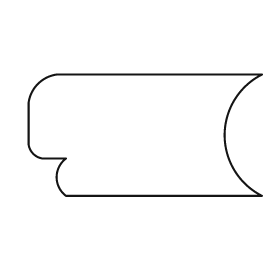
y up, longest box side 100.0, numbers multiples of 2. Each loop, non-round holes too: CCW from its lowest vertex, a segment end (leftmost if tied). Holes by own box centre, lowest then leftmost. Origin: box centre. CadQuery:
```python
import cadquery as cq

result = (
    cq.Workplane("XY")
    .moveTo(-34.0, -26.0)
    .lineTo(50.0, -26.0)
    .threePointArc((34.0, 0.0), (50.0, 26.0))
    .lineTo(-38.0, 26.0)
    .threePointArc((-46.0, 22.0), (-50.0, 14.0))
    .lineTo(-50.0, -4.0)
    .threePointArc((-48.0, -8.0), (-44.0, -10.0))
    .lineTo(-34.0, -10.0)
    .threePointArc((-38.0, -18.0), (-34.0, -26.0))
    .close()
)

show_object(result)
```